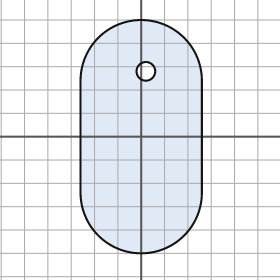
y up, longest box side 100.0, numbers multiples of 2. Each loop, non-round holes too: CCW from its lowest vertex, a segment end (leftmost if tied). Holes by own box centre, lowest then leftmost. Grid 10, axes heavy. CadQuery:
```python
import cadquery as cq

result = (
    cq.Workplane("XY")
    .moveTo(-26.0, -24.0)
    .threePointArc((0.0, -50.0), (26.0, -24.0))
    .lineTo(26.0, 24.0)
    .threePointArc((0.0, 50.0), (-26.0, 24.0))
    .close()
    .moveTo(2.0, 28.0)
    .circle(4.0)
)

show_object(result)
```